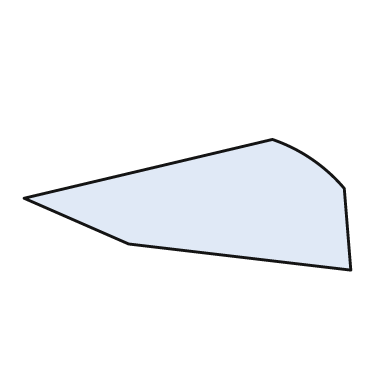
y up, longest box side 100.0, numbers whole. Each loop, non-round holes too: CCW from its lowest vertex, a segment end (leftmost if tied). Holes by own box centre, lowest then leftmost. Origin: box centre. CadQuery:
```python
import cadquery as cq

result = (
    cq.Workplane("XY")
    .moveTo(50.0, -20.0)
    .lineTo(48.0, 5.0)
    .threePointArc((38.0, 14.0), (26.0, 20.0))
    .lineTo(-50.0, 2.0)
    .lineTo(-18.0, -12.0)
    .close()
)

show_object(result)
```